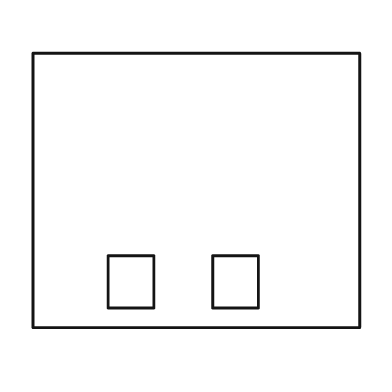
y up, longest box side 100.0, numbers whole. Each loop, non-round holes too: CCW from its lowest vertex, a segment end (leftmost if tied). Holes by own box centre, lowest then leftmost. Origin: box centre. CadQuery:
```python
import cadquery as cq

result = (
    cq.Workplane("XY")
    .moveTo(-50.0, -42.0)
    .lineTo(50.0, -42.0)
    .lineTo(50.0, 42.0)
    .lineTo(-50.0, 42.0)
    .close()
    .moveTo(-27.0, -36.0)
    .lineTo(-13.0, -36.0)
    .lineTo(-13.0, -20.0)
    .lineTo(-27.0, -20.0)
    .close()
    .moveTo(5.0, -36.0)
    .lineTo(19.0, -36.0)
    .lineTo(19.0, -20.0)
    .lineTo(5.0, -20.0)
    .close()
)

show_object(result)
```